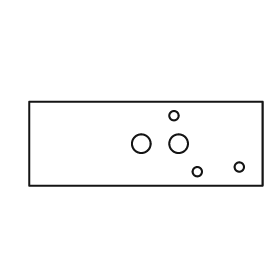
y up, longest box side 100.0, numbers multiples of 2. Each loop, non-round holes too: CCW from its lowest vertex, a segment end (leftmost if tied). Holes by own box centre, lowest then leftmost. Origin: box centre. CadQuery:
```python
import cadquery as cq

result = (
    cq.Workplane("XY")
    .moveTo(-50.0, -18.0)
    .lineTo(50.0, -18.0)
    .lineTo(50.0, 18.0)
    .lineTo(-50.0, 18.0)
    .close()
    .moveTo(22.0, -12.0)
    .circle(2.0)
    .moveTo(40.0, -10.0)
    .circle(2.0)
    .moveTo(-2.0, 0.0)
    .circle(4.0)
    .moveTo(14.0, 0.0)
    .circle(4.0)
    .moveTo(12.0, 12.0)
    .circle(2.0)
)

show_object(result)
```